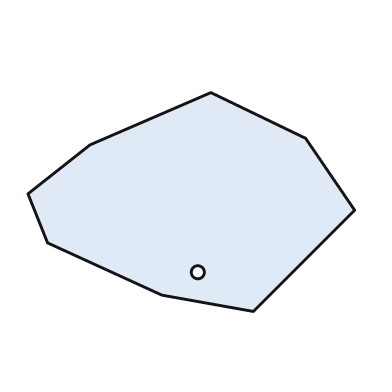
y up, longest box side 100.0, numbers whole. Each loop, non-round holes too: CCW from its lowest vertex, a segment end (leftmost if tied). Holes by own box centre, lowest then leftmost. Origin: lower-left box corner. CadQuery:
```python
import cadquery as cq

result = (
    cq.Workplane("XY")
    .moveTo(69.0, 0.0)
    .lineTo(100.0, 31.0)
    .lineTo(85.0, 53.0)
    .lineTo(56.0, 67.0)
    .lineTo(19.0, 51.0)
    .lineTo(0.0, 36.0)
    .lineTo(6.0, 21.0)
    .lineTo(41.0, 5.0)
    .close()
    .moveTo(52.0, 12.0)
    .circle(2.0)
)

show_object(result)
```